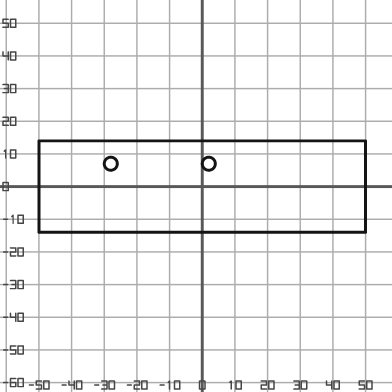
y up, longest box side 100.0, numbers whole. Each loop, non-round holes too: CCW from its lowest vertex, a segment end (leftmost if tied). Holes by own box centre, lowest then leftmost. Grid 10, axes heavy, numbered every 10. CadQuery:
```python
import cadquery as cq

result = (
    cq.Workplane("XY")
    .moveTo(-50.0, -14.0)
    .lineTo(50.0, -14.0)
    .lineTo(50.0, 14.0)
    .lineTo(-50.0, 14.0)
    .close()
    .moveTo(-28.0, 7.0)
    .circle(2.0)
    .moveTo(2.0, 7.0)
    .circle(2.0)
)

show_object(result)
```